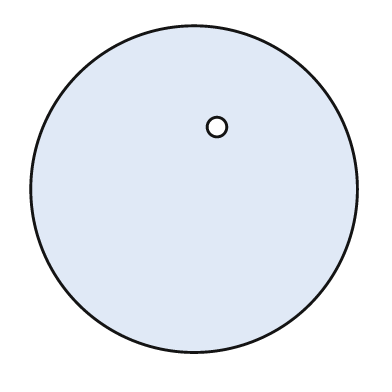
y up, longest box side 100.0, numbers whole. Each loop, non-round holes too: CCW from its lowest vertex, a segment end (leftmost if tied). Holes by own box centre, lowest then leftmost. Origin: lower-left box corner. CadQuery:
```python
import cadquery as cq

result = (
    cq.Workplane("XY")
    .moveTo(50.0, 50.0)
    .circle(50.0)
    .moveTo(57.0, 69.0)
    .circle(3.0)
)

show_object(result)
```